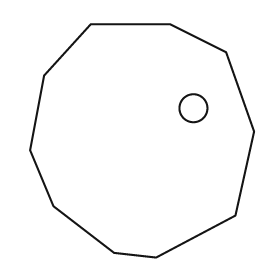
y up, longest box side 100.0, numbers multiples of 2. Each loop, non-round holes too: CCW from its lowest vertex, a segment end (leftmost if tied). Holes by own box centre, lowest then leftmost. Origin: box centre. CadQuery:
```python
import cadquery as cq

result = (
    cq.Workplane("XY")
    .moveTo(6.0, -50.0)
    .lineTo(40.0, -32.0)
    .lineTo(48.0, 4.0)
    .lineTo(36.0, 38.0)
    .lineTo(12.0, 50.0)
    .lineTo(-22.0, 50.0)
    .lineTo(-42.0, 28.0)
    .lineTo(-48.0, -4.0)
    .lineTo(-38.0, -28.0)
    .lineTo(-12.0, -48.0)
    .close()
    .moveTo(22.0, 14.0)
    .circle(6.0)
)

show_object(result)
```